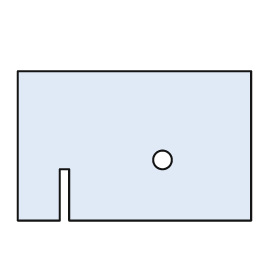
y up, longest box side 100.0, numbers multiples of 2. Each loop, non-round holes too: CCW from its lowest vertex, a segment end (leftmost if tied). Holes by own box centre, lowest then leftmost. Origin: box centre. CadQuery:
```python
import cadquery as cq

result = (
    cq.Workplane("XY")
    .moveTo(-50.0, -32.0)
    .lineTo(-32.0, -32.0)
    .lineTo(-32.0, -10.0)
    .lineTo(-28.0, -10.0)
    .lineTo(-28.0, -32.0)
    .lineTo(50.0, -32.0)
    .lineTo(50.0, 32.0)
    .lineTo(-50.0, 32.0)
    .close()
    .moveTo(12.0, -6.0)
    .circle(4.0)
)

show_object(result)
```